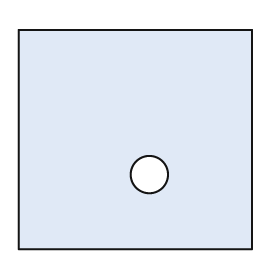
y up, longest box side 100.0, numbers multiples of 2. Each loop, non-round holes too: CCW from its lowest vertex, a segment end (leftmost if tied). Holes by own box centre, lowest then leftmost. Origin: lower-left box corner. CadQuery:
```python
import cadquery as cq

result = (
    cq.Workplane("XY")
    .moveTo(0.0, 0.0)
    .lineTo(100.0, 0.0)
    .lineTo(100.0, 94.0)
    .lineTo(0.0, 94.0)
    .close()
    .moveTo(56.0, 32.0)
    .circle(8.0)
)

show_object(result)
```